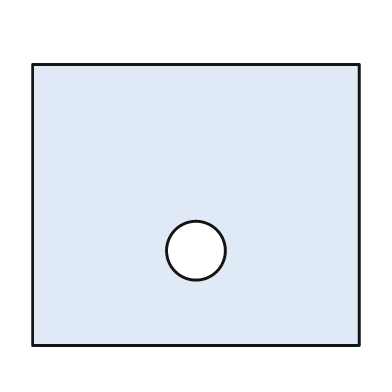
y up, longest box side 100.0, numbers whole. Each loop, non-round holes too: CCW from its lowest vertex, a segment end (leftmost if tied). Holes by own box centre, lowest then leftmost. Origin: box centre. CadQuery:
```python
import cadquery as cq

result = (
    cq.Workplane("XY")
    .moveTo(-50.0, -43.0)
    .lineTo(50.0, -43.0)
    .lineTo(50.0, 43.0)
    .lineTo(-50.0, 43.0)
    .close()
    .moveTo(0.0, -14.0)
    .circle(9.0)
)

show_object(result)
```